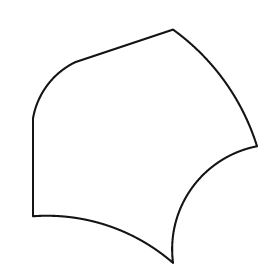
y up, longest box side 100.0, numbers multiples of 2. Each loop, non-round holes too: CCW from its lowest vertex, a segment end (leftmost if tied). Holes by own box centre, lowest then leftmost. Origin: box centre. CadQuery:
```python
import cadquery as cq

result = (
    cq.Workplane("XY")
    .moveTo(12.0, -50.0)
    .threePointArc((20.0, -18.0), (48.0, 0.0))
    .threePointArc((34.0, 28.0), (12.0, 50.0))
    .lineTo(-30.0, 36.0)
    .threePointArc((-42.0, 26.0), (-48.0, 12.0))
    .lineTo(-48.0, -30.0)
    .threePointArc((-16.0, -34.0), (12.0, -50.0))
    .close()
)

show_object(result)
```